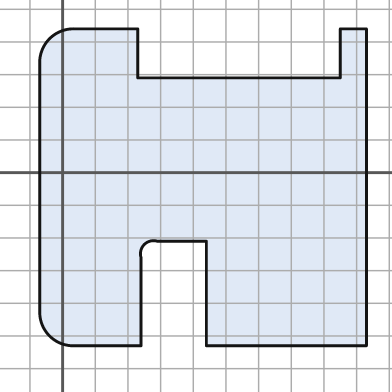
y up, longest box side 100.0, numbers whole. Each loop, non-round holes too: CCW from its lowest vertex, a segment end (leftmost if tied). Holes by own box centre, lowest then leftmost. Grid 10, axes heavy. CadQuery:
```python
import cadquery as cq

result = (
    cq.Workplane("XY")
    .moveTo(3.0, -53.0)
    .lineTo(24.0, -53.0)
    .lineTo(24.0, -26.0)
    .threePointArc((25.0, -22.0), (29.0, -21.0))
    .lineTo(44.0, -21.0)
    .lineTo(44.0, -53.0)
    .lineTo(93.0, -53.0)
    .lineTo(93.0, 44.0)
    .lineTo(85.0, 44.0)
    .lineTo(85.0, 29.0)
    .lineTo(23.0, 29.0)
    .lineTo(23.0, 44.0)
    .lineTo(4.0, 44.0)
    .threePointArc((-4.0, 41.0), (-7.0, 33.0))
    .lineTo(-7.0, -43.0)
    .threePointArc((-4.0, -50.0), (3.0, -53.0))
    .close()
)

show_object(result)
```